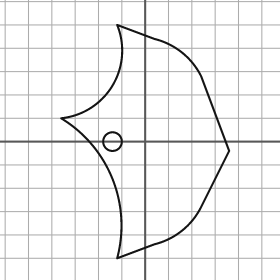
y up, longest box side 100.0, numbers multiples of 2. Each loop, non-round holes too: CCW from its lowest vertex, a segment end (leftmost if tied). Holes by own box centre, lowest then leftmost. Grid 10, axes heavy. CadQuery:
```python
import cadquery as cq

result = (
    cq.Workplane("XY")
    .moveTo(-12.0, -50.0)
    .lineTo(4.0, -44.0)
    .threePointArc((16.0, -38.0), (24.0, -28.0))
    .lineTo(36.0, -4.0)
    .lineTo(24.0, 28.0)
    .threePointArc((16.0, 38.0), (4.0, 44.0))
    .lineTo(-12.0, 50.0)
    .threePointArc((-14.0, 24.0), (-36.0, 10.0))
    .threePointArc((-14.0, -16.0), (-12.0, -50.0))
    .close()
    .moveTo(-14.0, 0.0)
    .circle(4.0)
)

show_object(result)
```